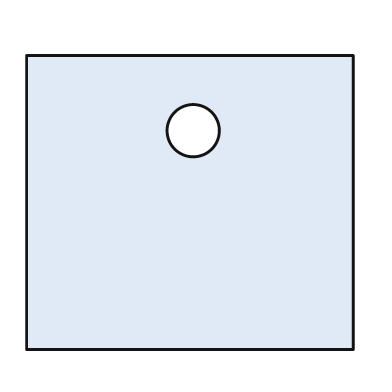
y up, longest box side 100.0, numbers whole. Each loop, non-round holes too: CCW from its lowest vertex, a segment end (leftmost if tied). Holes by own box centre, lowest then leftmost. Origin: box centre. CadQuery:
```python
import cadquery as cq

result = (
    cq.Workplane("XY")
    .moveTo(-50.0, -45.0)
    .lineTo(50.0, -45.0)
    .lineTo(50.0, 45.0)
    .lineTo(-50.0, 45.0)
    .close()
    .moveTo(1.0, 22.0)
    .circle(8.0)
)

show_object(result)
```